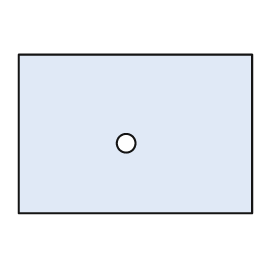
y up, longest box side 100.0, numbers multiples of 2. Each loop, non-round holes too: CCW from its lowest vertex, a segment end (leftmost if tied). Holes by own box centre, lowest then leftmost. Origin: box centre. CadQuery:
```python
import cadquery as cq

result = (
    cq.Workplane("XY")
    .moveTo(-50.0, -34.0)
    .lineTo(50.0, -34.0)
    .lineTo(50.0, 34.0)
    .lineTo(-50.0, 34.0)
    .close()
    .moveTo(-4.0, -4.0)
    .circle(4.0)
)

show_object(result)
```